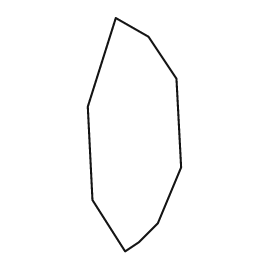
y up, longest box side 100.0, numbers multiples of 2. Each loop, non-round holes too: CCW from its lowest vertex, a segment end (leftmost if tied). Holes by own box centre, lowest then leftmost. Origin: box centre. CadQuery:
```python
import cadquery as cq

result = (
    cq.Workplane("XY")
    .moveTo(-4.0, -50.0)
    .lineTo(2.0, -46.0)
    .lineTo(10.0, -38.0)
    .lineTo(20.0, -14.0)
    .lineTo(18.0, 24.0)
    .lineTo(6.0, 42.0)
    .lineTo(-8.0, 50.0)
    .lineTo(-20.0, 12.0)
    .lineTo(-18.0, -28.0)
    .close()
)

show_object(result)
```